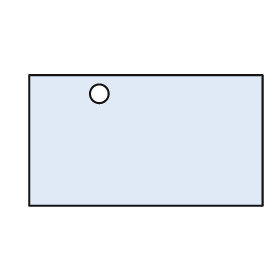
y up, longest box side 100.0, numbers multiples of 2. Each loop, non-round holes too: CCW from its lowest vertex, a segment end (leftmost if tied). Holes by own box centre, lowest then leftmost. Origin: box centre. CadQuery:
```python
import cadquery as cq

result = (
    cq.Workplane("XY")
    .moveTo(-50.0, -28.0)
    .lineTo(50.0, -28.0)
    .lineTo(50.0, 28.0)
    .lineTo(-50.0, 28.0)
    .close()
    .moveTo(-20.0, 20.0)
    .circle(4.0)
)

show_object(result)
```